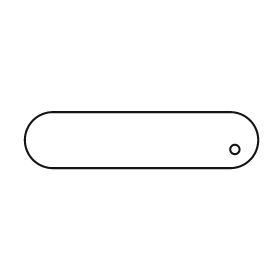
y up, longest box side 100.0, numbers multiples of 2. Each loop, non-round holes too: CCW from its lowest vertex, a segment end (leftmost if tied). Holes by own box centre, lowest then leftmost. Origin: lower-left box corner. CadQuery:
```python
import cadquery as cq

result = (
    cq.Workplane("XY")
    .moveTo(12.0, 0.0)
    .lineTo(88.0, 0.0)
    .threePointArc((100.0, 12.0), (88.0, 24.0))
    .lineTo(12.0, 24.0)
    .threePointArc((0.0, 12.0), (12.0, 0.0))
    .close()
    .moveTo(90.0, 8.0)
    .circle(2.0)
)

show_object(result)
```